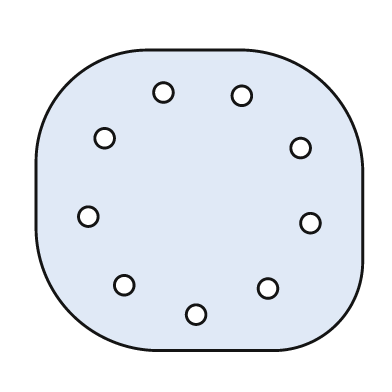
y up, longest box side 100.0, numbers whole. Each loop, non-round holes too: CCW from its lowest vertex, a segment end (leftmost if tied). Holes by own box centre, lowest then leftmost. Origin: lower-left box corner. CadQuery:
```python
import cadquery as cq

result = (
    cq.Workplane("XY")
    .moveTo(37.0, 0.0)
    .lineTo(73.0, 0.0)
    .threePointArc((92.0, 8.0), (100.0, 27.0))
    .lineTo(100.0, 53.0)
    .threePointArc((89.0, 81.0), (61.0, 92.0))
    .lineTo(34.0, 92.0)
    .threePointArc((10.0, 82.0), (0.0, 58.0))
    .lineTo(0.0, 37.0)
    .threePointArc((11.0, 11.0), (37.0, 0.0))
    .close()
    .moveTo(49.0, 11.0)
    .circle(3.0)
    .moveTo(71.0, 19.0)
    .circle(3.0)
    .moveTo(27.0, 20.0)
    .circle(3.0)
    .moveTo(84.0, 39.0)
    .circle(3.0)
    .moveTo(16.0, 41.0)
    .circle(3.0)
    .moveTo(81.0, 62.0)
    .circle(3.0)
    .moveTo(21.0, 65.0)
    .circle(3.0)
    .moveTo(63.0, 78.0)
    .circle(3.0)
    .moveTo(39.0, 79.0)
    .circle(3.0)
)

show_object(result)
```